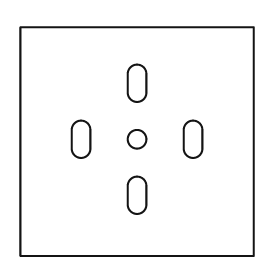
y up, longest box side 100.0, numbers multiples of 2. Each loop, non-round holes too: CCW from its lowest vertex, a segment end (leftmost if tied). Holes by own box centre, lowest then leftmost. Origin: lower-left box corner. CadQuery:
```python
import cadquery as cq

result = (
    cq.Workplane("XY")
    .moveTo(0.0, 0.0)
    .lineTo(100.0, 0.0)
    .lineTo(100.0, 98.0)
    .lineTo(0.0, 98.0)
    .close()
    .moveTo(46.0, 22.0)
    .threePointArc((50.0, 18.0), (54.0, 22.0))
    .lineTo(54.0, 30.0)
    .threePointArc((50.0, 34.0), (46.0, 30.0))
    .close()
    .moveTo(22.0, 46.0)
    .threePointArc((26.0, 42.0), (30.0, 46.0))
    .lineTo(30.0, 54.0)
    .threePointArc((26.0, 58.0), (22.0, 54.0))
    .close()
    .moveTo(50.0, 50.0)
    .circle(4.0)
    .moveTo(70.0, 46.0)
    .threePointArc((74.0, 42.0), (78.0, 46.0))
    .lineTo(78.0, 54.0)
    .threePointArc((74.0, 58.0), (70.0, 54.0))
    .close()
    .moveTo(46.0, 70.0)
    .threePointArc((50.0, 66.0), (54.0, 70.0))
    .lineTo(54.0, 78.0)
    .threePointArc((50.0, 82.0), (46.0, 78.0))
    .close()
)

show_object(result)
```